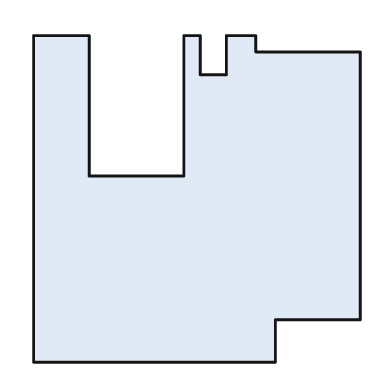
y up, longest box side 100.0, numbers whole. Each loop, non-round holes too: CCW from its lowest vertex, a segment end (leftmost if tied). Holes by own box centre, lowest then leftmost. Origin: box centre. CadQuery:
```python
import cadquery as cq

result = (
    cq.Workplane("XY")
    .moveTo(-50.0, -50.0)
    .lineTo(24.0, -50.0)
    .lineTo(24.0, -37.0)
    .lineTo(50.0, -37.0)
    .lineTo(50.0, 45.0)
    .lineTo(18.0, 45.0)
    .lineTo(18.0, 50.0)
    .lineTo(9.0, 50.0)
    .lineTo(9.0, 38.0)
    .lineTo(1.0, 38.0)
    .lineTo(1.0, 50.0)
    .lineTo(-4.0, 50.0)
    .lineTo(-4.0, 7.0)
    .lineTo(-33.0, 7.0)
    .lineTo(-33.0, 50.0)
    .lineTo(-50.0, 50.0)
    .close()
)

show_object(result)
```